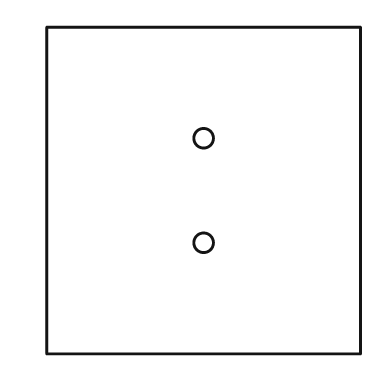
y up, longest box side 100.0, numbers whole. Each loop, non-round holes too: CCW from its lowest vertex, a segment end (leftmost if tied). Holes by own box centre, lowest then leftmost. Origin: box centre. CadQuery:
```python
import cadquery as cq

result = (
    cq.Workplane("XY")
    .moveTo(-48.0, -50.0)
    .lineTo(48.0, -50.0)
    .lineTo(48.0, 50.0)
    .lineTo(-48.0, 50.0)
    .close()
    .moveTo(0.0, -16.0)
    .circle(3.0)
    .moveTo(0.0, 16.0)
    .circle(3.0)
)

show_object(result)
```